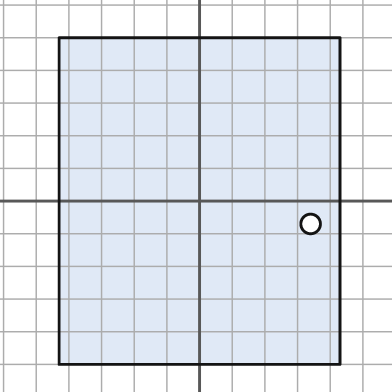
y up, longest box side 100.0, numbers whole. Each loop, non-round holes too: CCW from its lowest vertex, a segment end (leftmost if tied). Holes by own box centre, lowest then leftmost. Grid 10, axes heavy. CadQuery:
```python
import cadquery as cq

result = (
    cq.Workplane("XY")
    .moveTo(-43.0, -50.0)
    .lineTo(43.0, -50.0)
    .lineTo(43.0, 50.0)
    .lineTo(-43.0, 50.0)
    .close()
    .moveTo(34.0, -7.0)
    .circle(3.0)
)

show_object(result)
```